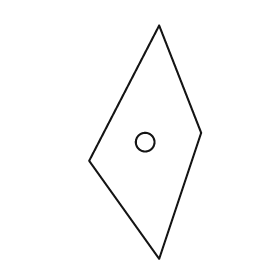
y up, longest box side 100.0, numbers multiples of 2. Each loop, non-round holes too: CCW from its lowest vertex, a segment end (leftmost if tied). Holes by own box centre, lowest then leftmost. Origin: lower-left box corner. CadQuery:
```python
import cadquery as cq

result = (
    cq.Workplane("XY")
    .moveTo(30.0, 0.0)
    .lineTo(48.0, 54.0)
    .lineTo(30.0, 100.0)
    .lineTo(0.0, 42.0)
    .close()
    .moveTo(24.0, 50.0)
    .circle(4.0)
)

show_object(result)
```